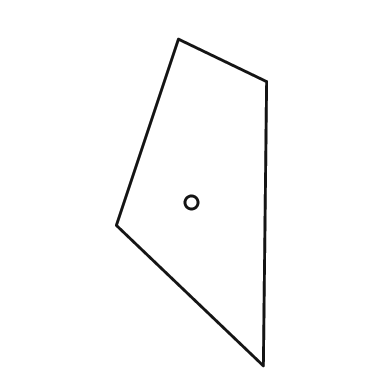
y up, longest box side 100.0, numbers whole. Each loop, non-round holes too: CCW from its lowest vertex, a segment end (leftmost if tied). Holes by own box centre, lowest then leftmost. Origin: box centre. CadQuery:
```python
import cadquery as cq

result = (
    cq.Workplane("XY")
    .moveTo(22.0, -50.0)
    .lineTo(23.0, 37.0)
    .lineTo(-4.0, 50.0)
    .lineTo(-23.0, -7.0)
    .close()
    .moveTo(0.0, 0.0)
    .circle(2.0)
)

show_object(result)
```